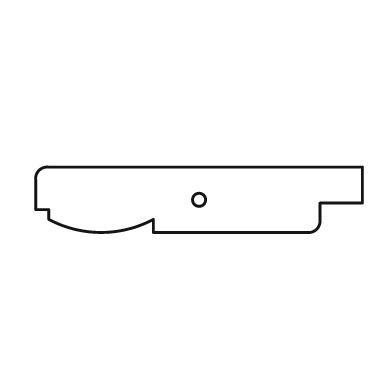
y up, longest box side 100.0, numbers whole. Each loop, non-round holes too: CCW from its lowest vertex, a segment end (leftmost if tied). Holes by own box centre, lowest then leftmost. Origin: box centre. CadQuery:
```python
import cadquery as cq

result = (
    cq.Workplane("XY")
    .moveTo(-14.0, -10.0)
    .lineTo(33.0, -10.0)
    .threePointArc((36.0, -9.0), (37.0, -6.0))
    .lineTo(37.0, -1.0)
    .lineTo(50.0, -1.0)
    .lineTo(50.0, 10.0)
    .lineTo(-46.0, 10.0)
    .threePointArc((-49.0, 9.0), (-50.0, 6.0))
    .lineTo(-50.0, -3.0)
    .lineTo(-46.0, -3.0)
    .lineTo(-46.0, -6.0)
    .threePointArc((-30.0, -10.0), (-14.0, -6.0))
    .close()
    .moveTo(0.0, 0.0)
    .circle(2.0)
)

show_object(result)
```